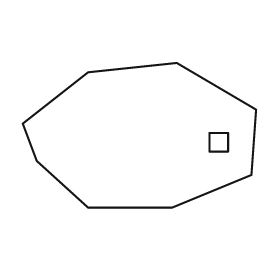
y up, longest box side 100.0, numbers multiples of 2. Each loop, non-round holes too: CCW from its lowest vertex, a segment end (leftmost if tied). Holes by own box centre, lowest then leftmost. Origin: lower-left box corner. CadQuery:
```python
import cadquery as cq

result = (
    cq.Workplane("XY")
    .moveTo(28.0, 0.0)
    .lineTo(64.0, 0.0)
    .lineTo(98.0, 14.0)
    .lineTo(100.0, 42.0)
    .lineTo(66.0, 62.0)
    .lineTo(28.0, 58.0)
    .lineTo(0.0, 36.0)
    .lineTo(6.0, 20.0)
    .close()
    .moveTo(80.0, 24.0)
    .lineTo(88.0, 24.0)
    .lineTo(88.0, 32.0)
    .lineTo(80.0, 32.0)
    .close()
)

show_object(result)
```